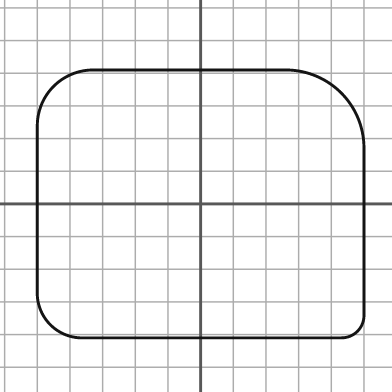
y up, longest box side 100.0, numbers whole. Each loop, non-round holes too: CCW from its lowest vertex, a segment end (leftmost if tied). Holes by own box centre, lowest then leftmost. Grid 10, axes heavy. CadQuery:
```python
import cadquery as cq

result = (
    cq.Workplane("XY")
    .moveTo(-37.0, -41.0)
    .lineTo(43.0, -41.0)
    .threePointArc((48.0, -39.0), (50.0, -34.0))
    .lineTo(50.0, 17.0)
    .threePointArc((43.0, 34.0), (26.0, 41.0))
    .lineTo(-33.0, 41.0)
    .threePointArc((-45.0, 36.0), (-50.0, 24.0))
    .lineTo(-50.0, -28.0)
    .threePointArc((-46.0, -37.0), (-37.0, -41.0))
    .close()
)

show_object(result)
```